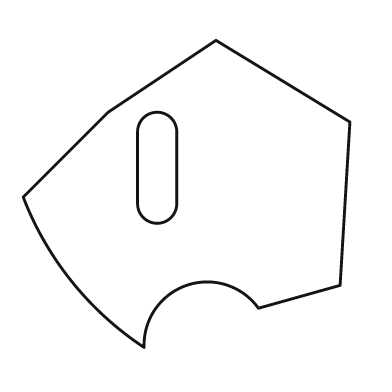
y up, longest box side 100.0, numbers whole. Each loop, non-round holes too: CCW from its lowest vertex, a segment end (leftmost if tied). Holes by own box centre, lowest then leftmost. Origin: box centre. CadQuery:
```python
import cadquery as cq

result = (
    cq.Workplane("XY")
    .moveTo(-13.0, -47.0)
    .threePointArc((0.0, -28.0), (22.0, -35.0))
    .lineTo(47.0, -28.0)
    .lineTo(50.0, 22.0)
    .lineTo(9.0, 47.0)
    .lineTo(-24.0, 25.0)
    .lineTo(-50.0, -1.0)
    .threePointArc((-35.0, -27.0), (-13.0, -47.0))
    .close()
    .moveTo(-15.0, -3.0)
    .threePointArc((-9.0, -9.0), (-3.0, -3.0))
    .lineTo(-3.0, 19.0)
    .threePointArc((-9.0, 25.0), (-15.0, 19.0))
    .close()
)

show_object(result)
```